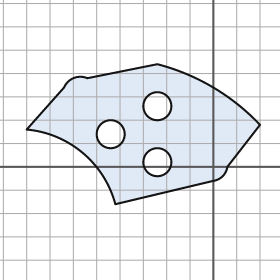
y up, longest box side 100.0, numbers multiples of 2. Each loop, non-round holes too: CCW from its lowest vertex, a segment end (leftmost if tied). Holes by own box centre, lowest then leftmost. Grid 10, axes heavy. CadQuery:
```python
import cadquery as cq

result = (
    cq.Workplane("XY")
    .moveTo(-42.0, -16.0)
    .lineTo(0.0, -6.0)
    .threePointArc((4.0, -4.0), (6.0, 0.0))
    .lineTo(20.0, 18.0)
    .threePointArc((0.0, 34.0), (-24.0, 44.0))
    .lineTo(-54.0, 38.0)
    .threePointArc((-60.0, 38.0), (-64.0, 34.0))
    .lineTo(-80.0, 16.0)
    .threePointArc((-56.0, 6.0), (-42.0, -16.0))
    .close()
    .moveTo(-24.0, 2.0)
    .circle(6.0)
    .moveTo(-44.0, 14.0)
    .circle(6.0)
    .moveTo(-24.0, 26.0)
    .circle(6.0)
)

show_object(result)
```